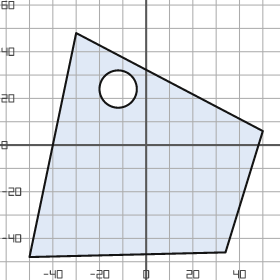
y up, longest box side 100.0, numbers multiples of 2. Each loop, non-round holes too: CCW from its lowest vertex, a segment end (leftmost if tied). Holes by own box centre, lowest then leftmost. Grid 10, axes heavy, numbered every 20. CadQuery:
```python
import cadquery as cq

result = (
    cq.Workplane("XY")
    .moveTo(-50.0, -48.0)
    .lineTo(34.0, -46.0)
    .lineTo(50.0, 6.0)
    .lineTo(-30.0, 48.0)
    .close()
    .moveTo(-12.0, 24.0)
    .circle(8.0)
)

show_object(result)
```